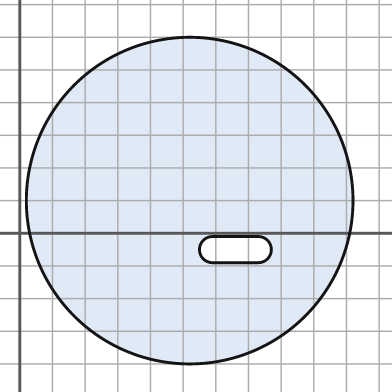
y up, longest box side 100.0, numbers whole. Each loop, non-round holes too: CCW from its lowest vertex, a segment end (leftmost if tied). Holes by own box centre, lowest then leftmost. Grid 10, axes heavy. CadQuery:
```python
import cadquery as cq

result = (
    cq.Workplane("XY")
    .moveTo(52.0, 10.0)
    .circle(50.0)
    .moveTo(59.0, -9.0)
    .lineTo(73.0, -9.0)
    .threePointArc((77.0, -5.0), (73.0, -1.0))
    .lineTo(59.0, -1.0)
    .threePointArc((55.0, -5.0), (59.0, -9.0))
    .close()
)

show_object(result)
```